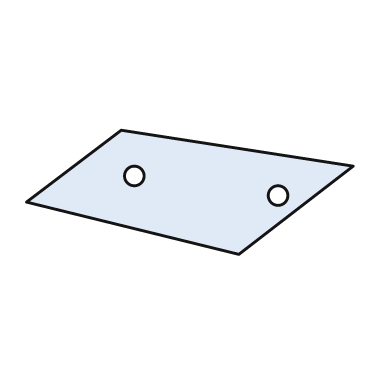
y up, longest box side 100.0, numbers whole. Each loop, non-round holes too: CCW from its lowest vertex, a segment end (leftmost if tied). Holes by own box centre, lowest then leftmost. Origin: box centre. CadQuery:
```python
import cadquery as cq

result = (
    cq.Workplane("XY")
    .moveTo(15.0, -19.0)
    .lineTo(50.0, 8.0)
    .lineTo(-21.0, 19.0)
    .lineTo(-50.0, -3.0)
    .close()
    .moveTo(27.0, -1.0)
    .circle(3.0)
    .moveTo(-17.0, 5.0)
    .circle(3.0)
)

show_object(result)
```